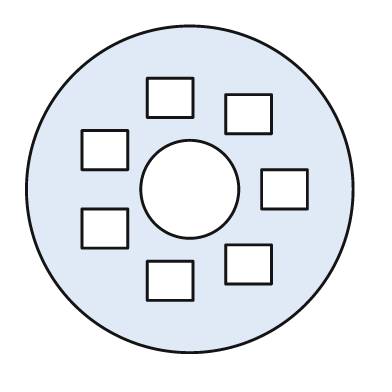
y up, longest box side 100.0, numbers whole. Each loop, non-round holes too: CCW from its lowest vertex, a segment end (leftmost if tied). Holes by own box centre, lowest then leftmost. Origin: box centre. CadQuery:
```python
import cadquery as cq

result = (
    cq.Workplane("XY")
    .moveTo(0.0, 0.0)
    .circle(50.0)
    .moveTo(-13.0, -34.0)
    .lineTo(1.0, -34.0)
    .lineTo(1.0, -22.0)
    .lineTo(-13.0, -22.0)
    .close()
    .moveTo(11.0, -29.0)
    .lineTo(25.0, -29.0)
    .lineTo(25.0, -17.0)
    .lineTo(11.0, -17.0)
    .close()
    .moveTo(-33.0, -18.0)
    .lineTo(-19.0, -18.0)
    .lineTo(-19.0, -6.0)
    .lineTo(-33.0, -6.0)
    .close()
    .moveTo(0.0, 0.0)
    .circle(15.0)
    .moveTo(22.0, -6.0)
    .lineTo(36.0, -6.0)
    .lineTo(36.0, 6.0)
    .lineTo(22.0, 6.0)
    .close()
    .moveTo(-33.0, 6.0)
    .lineTo(-19.0, 6.0)
    .lineTo(-19.0, 18.0)
    .lineTo(-33.0, 18.0)
    .close()
    .moveTo(11.0, 17.0)
    .lineTo(25.0, 17.0)
    .lineTo(25.0, 29.0)
    .lineTo(11.0, 29.0)
    .close()
    .moveTo(-13.0, 22.0)
    .lineTo(1.0, 22.0)
    .lineTo(1.0, 34.0)
    .lineTo(-13.0, 34.0)
    .close()
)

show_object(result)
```